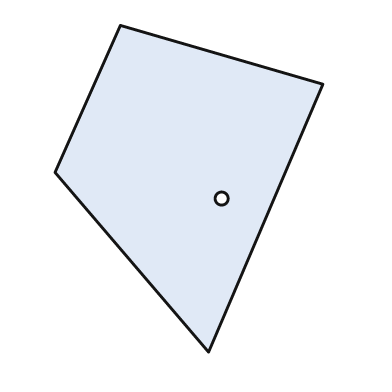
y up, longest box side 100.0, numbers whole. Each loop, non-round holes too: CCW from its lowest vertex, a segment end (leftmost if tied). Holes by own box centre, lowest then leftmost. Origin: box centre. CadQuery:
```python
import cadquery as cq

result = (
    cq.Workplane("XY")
    .moveTo(6.0, -50.0)
    .lineTo(41.0, 32.0)
    .lineTo(-21.0, 50.0)
    .lineTo(-41.0, 5.0)
    .close()
    .moveTo(10.0, -3.0)
    .circle(2.0)
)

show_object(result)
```